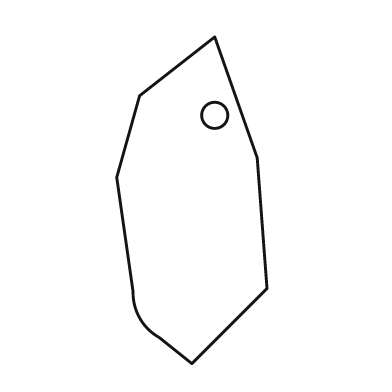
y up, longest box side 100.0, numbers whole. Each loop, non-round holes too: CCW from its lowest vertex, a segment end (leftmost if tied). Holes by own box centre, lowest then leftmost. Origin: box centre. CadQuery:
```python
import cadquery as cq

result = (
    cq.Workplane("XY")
    .moveTo(0.0, -50.0)
    .lineTo(23.0, -27.0)
    .lineTo(20.0, 13.0)
    .lineTo(7.0, 50.0)
    .lineTo(-16.0, 32.0)
    .lineTo(-23.0, 7.0)
    .lineTo(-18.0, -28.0)
    .threePointArc((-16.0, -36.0), (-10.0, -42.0))
    .close()
    .moveTo(7.0, 26.0)
    .circle(4.0)
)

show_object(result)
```